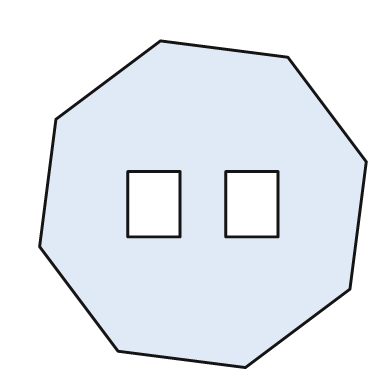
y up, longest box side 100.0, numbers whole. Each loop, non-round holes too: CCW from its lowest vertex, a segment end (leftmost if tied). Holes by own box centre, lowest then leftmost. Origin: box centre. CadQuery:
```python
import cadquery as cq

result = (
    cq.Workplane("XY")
    .moveTo(13.0, -50.0)
    .lineTo(45.0, -26.0)
    .lineTo(50.0, 13.0)
    .lineTo(26.0, 45.0)
    .lineTo(-13.0, 50.0)
    .lineTo(-45.0, 26.0)
    .lineTo(-50.0, -13.0)
    .lineTo(-26.0, -45.0)
    .close()
    .moveTo(-23.0, -10.0)
    .lineTo(-7.0, -10.0)
    .lineTo(-7.0, 10.0)
    .lineTo(-23.0, 10.0)
    .close()
    .moveTo(7.0, -10.0)
    .lineTo(23.0, -10.0)
    .lineTo(23.0, 10.0)
    .lineTo(7.0, 10.0)
    .close()
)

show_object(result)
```